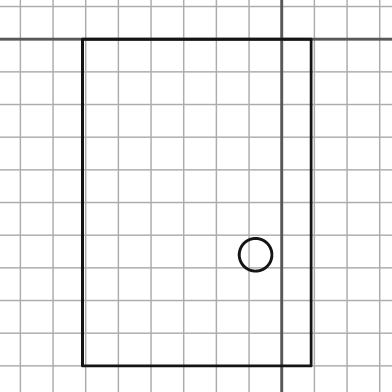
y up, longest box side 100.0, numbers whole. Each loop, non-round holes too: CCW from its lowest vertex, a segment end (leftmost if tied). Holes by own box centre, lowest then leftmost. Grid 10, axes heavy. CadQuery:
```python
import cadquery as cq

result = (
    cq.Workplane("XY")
    .moveTo(-61.0, -100.0)
    .lineTo(9.0, -100.0)
    .lineTo(9.0, 0.0)
    .lineTo(-61.0, 0.0)
    .close()
    .moveTo(-8.0, -66.0)
    .circle(5.0)
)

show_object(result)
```